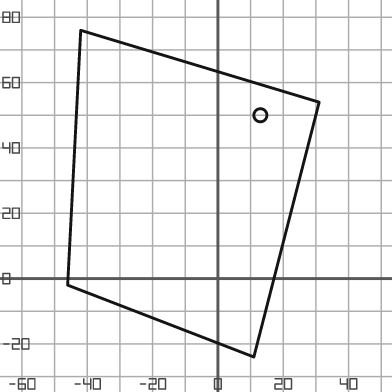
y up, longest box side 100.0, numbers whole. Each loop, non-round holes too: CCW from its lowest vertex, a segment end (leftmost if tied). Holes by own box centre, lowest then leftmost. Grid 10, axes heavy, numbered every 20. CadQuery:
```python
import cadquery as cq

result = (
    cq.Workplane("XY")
    .moveTo(11.0, -24.0)
    .lineTo(31.0, 54.0)
    .lineTo(-42.0, 76.0)
    .lineTo(-46.0, -2.0)
    .close()
    .moveTo(13.0, 50.0)
    .circle(2.0)
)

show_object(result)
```